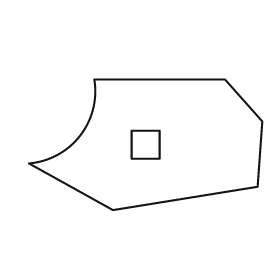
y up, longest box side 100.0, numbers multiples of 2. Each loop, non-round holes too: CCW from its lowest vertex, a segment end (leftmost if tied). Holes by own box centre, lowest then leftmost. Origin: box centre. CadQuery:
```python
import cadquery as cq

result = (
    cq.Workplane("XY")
    .moveTo(-14.0, -28.0)
    .lineTo(48.0, -18.0)
    .lineTo(50.0, 10.0)
    .lineTo(34.0, 28.0)
    .lineTo(-22.0, 28.0)
    .threePointArc((-28.0, 4.0), (-50.0, -8.0))
    .close()
    .moveTo(-6.0, -6.0)
    .lineTo(6.0, -6.0)
    .lineTo(6.0, 6.0)
    .lineTo(-6.0, 6.0)
    .close()
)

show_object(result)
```